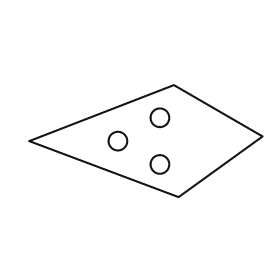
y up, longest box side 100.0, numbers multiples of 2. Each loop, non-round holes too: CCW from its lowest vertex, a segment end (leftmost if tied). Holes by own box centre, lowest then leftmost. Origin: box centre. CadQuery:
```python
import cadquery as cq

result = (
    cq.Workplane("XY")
    .moveTo(14.0, -24.0)
    .lineTo(50.0, 2.0)
    .lineTo(12.0, 24.0)
    .lineTo(-50.0, 0.0)
    .close()
    .moveTo(6.0, -10.0)
    .circle(4.0)
    .moveTo(-12.0, 0.0)
    .circle(4.0)
    .moveTo(6.0, 10.0)
    .circle(4.0)
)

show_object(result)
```